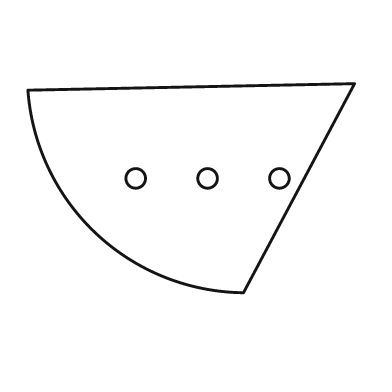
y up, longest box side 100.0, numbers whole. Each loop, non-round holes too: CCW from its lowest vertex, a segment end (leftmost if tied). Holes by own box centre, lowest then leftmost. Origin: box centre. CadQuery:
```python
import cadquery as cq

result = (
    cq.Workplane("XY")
    .moveTo(16.0, -32.0)
    .lineTo(50.0, 32.0)
    .lineTo(-50.0, 30.0)
    .threePointArc((-29.0, -14.0), (16.0, -32.0))
    .close()
    .moveTo(-17.0, 3.0)
    .circle(3.0)
    .moveTo(5.0, 3.0)
    .circle(3.0)
    .moveTo(27.0, 3.0)
    .circle(3.0)
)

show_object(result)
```